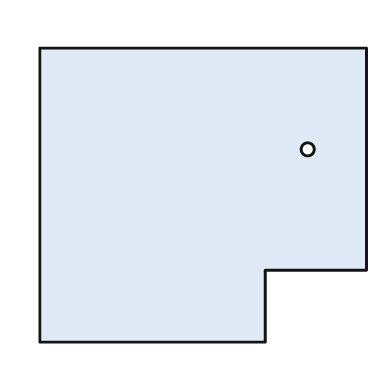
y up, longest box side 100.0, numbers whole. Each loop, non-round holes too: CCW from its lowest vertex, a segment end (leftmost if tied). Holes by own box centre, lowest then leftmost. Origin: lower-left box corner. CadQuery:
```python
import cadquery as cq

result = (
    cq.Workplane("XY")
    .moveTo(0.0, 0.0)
    .lineTo(69.0, 0.0)
    .lineTo(69.0, 22.0)
    .lineTo(100.0, 22.0)
    .lineTo(100.0, 90.0)
    .lineTo(0.0, 90.0)
    .close()
    .moveTo(82.0, 59.0)
    .circle(2.0)
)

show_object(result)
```